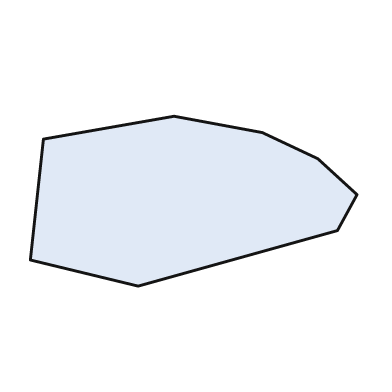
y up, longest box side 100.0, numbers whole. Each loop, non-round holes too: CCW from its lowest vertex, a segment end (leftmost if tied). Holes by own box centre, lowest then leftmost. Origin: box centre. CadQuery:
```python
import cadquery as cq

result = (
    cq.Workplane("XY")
    .moveTo(-17.0, -26.0)
    .lineTo(44.0, -9.0)
    .lineTo(50.0, 2.0)
    .lineTo(38.0, 13.0)
    .lineTo(21.0, 21.0)
    .lineTo(-6.0, 26.0)
    .lineTo(-46.0, 19.0)
    .lineTo(-50.0, -18.0)
    .close()
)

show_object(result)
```